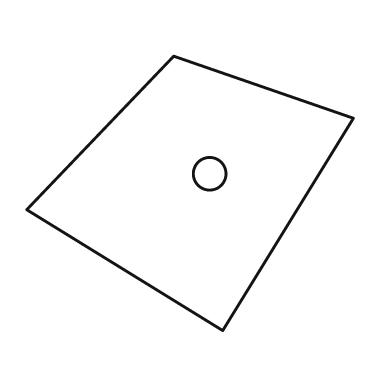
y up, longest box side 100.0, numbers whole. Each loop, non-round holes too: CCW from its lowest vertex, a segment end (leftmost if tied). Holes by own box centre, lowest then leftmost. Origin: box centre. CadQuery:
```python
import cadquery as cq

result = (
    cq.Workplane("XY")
    .moveTo(10.0, -42.0)
    .lineTo(50.0, 23.0)
    .lineTo(-5.0, 42.0)
    .lineTo(-50.0, -5.0)
    .close()
    .moveTo(6.0, 6.0)
    .circle(5.0)
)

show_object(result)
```